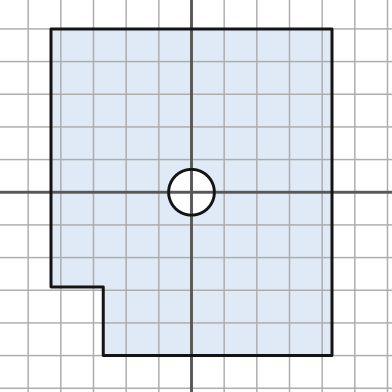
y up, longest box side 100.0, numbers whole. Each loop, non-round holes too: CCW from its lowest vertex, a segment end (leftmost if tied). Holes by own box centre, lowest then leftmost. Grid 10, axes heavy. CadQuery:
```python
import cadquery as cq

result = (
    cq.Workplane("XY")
    .moveTo(-27.0, -50.0)
    .lineTo(43.0, -50.0)
    .lineTo(43.0, 50.0)
    .lineTo(-43.0, 50.0)
    .lineTo(-43.0, -29.0)
    .lineTo(-27.0, -29.0)
    .close()
    .moveTo(0.0, 0.0)
    .circle(7.0)
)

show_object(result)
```